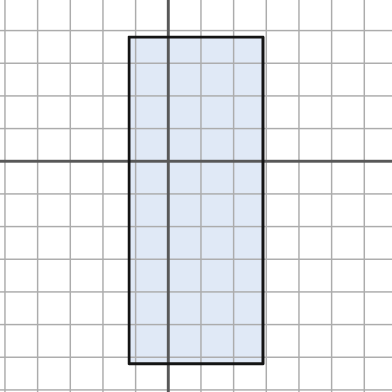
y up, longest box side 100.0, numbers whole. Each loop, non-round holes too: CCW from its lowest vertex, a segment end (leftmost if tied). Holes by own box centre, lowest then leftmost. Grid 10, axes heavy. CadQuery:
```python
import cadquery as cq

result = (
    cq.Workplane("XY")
    .moveTo(-12.0, -62.0)
    .lineTo(29.0, -62.0)
    .lineTo(29.0, 38.0)
    .lineTo(-12.0, 38.0)
    .close()
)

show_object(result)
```